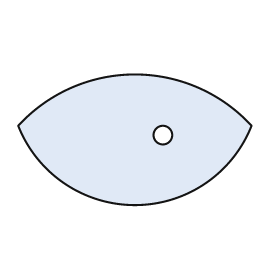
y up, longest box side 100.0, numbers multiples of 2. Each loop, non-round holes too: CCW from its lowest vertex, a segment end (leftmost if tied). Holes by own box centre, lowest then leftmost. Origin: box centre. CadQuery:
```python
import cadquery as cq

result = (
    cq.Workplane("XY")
    .moveTo(-50.0, 6.0)
    .threePointArc((0.0, -28.0), (50.0, 6.0))
    .threePointArc((0.0, 28.0), (-50.0, 6.0))
    .close()
    .moveTo(12.0, 2.0)
    .circle(4.0)
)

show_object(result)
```